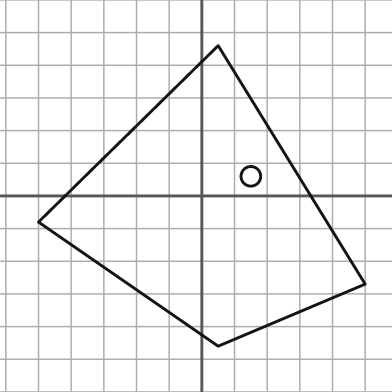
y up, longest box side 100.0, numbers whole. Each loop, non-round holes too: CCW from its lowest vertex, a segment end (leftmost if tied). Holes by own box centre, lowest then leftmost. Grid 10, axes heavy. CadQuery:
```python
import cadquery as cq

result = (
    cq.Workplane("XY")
    .moveTo(5.0, -46.0)
    .lineTo(50.0, -27.0)
    .lineTo(5.0, 46.0)
    .lineTo(-50.0, -8.0)
    .close()
    .moveTo(15.0, 6.0)
    .circle(3.0)
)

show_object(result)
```